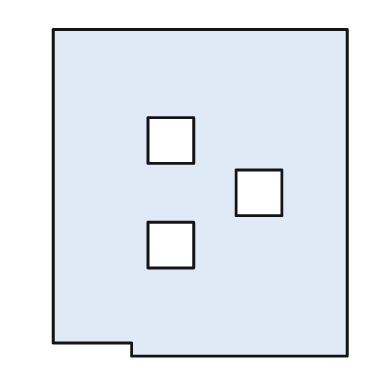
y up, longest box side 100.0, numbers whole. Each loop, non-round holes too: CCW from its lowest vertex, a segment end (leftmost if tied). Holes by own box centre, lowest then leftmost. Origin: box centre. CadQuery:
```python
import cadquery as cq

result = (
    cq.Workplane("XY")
    .moveTo(-21.0, -50.0)
    .lineTo(45.0, -50.0)
    .lineTo(45.0, 50.0)
    .lineTo(-45.0, 50.0)
    .lineTo(-45.0, -46.0)
    .lineTo(-21.0, -46.0)
    .close()
    .moveTo(-16.0, -23.0)
    .lineTo(-2.0, -23.0)
    .lineTo(-2.0, -9.0)
    .lineTo(-16.0, -9.0)
    .close()
    .moveTo(11.0, -7.0)
    .lineTo(25.0, -7.0)
    .lineTo(25.0, 7.0)
    .lineTo(11.0, 7.0)
    .close()
    .moveTo(-16.0, 9.0)
    .lineTo(-2.0, 9.0)
    .lineTo(-2.0, 23.0)
    .lineTo(-16.0, 23.0)
    .close()
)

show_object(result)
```